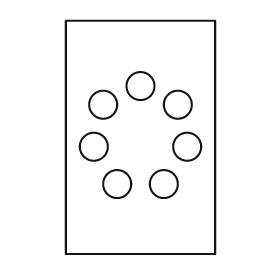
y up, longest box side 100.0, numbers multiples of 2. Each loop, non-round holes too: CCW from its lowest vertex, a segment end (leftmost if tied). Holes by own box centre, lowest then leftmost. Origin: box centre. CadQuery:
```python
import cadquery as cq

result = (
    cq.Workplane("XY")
    .moveTo(-32.0, -50.0)
    .lineTo(32.0, -50.0)
    .lineTo(32.0, 50.0)
    .lineTo(-32.0, 50.0)
    .close()
    .moveTo(-10.0, -20.0)
    .circle(6.0)
    .moveTo(10.0, -20.0)
    .circle(6.0)
    .moveTo(-20.0, -4.0)
    .circle(6.0)
    .moveTo(20.0, -4.0)
    .circle(6.0)
    .moveTo(-16.0, 14.0)
    .circle(6.0)
    .moveTo(16.0, 14.0)
    .circle(6.0)
    .moveTo(0.0, 22.0)
    .circle(6.0)
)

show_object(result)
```